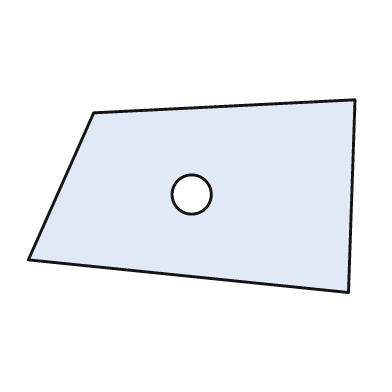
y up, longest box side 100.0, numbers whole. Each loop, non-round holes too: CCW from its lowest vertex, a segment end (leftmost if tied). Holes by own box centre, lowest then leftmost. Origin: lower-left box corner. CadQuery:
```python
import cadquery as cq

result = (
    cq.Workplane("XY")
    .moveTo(98.0, 0.0)
    .lineTo(100.0, 59.0)
    .lineTo(20.0, 55.0)
    .lineTo(0.0, 10.0)
    .close()
    .moveTo(50.0, 30.0)
    .circle(6.0)
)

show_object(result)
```